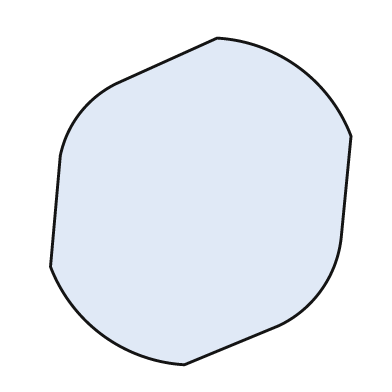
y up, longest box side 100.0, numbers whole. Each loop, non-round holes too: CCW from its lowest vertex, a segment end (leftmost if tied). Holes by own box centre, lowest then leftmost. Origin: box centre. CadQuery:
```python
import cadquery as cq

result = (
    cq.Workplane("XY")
    .moveTo(-5.0, -50.0)
    .lineTo(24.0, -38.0)
    .threePointArc((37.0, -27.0), (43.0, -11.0))
    .lineTo(46.0, 20.0)
    .threePointArc((30.0, 41.0), (5.0, 50.0))
    .lineTo(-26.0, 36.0)
    .threePointArc((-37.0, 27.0), (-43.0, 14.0))
    .lineTo(-46.0, -20.0)
    .threePointArc((-30.0, -41.0), (-5.0, -50.0))
    .close()
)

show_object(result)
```